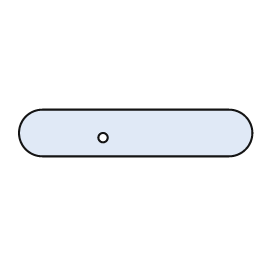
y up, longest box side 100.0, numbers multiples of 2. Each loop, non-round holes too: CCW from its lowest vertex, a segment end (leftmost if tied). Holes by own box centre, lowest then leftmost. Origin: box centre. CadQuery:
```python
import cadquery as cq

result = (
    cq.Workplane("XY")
    .moveTo(-40.0, -10.0)
    .lineTo(40.0, -10.0)
    .threePointArc((50.0, 0.0), (40.0, 10.0))
    .lineTo(-40.0, 10.0)
    .threePointArc((-50.0, 0.0), (-40.0, -10.0))
    .close()
    .moveTo(-14.0, -2.0)
    .circle(2.0)
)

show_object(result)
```